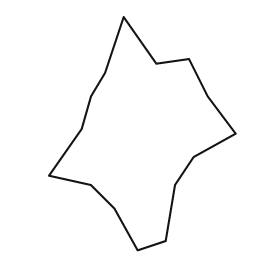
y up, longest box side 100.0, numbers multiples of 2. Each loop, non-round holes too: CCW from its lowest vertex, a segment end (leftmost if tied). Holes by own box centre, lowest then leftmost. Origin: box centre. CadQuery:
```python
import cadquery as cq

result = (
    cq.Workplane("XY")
    .moveTo(-2.0, -50.0)
    .lineTo(10.0, -46.0)
    .lineTo(14.0, -22.0)
    .lineTo(22.0, -10.0)
    .lineTo(40.0, 0.0)
    .lineTo(28.0, 16.0)
    .lineTo(20.0, 32.0)
    .lineTo(6.0, 30.0)
    .lineTo(-8.0, 50.0)
    .lineTo(-16.0, 26.0)
    .lineTo(-22.0, 16.0)
    .lineTo(-26.0, 2.0)
    .lineTo(-40.0, -18.0)
    .lineTo(-22.0, -22.0)
    .lineTo(-12.0, -32.0)
    .close()
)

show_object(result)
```